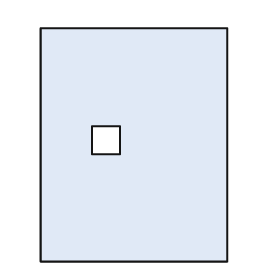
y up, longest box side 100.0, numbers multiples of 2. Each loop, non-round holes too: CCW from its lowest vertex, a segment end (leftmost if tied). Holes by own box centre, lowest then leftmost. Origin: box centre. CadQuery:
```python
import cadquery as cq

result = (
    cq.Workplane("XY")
    .moveTo(-40.0, -50.0)
    .lineTo(40.0, -50.0)
    .lineTo(40.0, 50.0)
    .lineTo(-40.0, 50.0)
    .close()
    .moveTo(-18.0, -4.0)
    .lineTo(-6.0, -4.0)
    .lineTo(-6.0, 8.0)
    .lineTo(-18.0, 8.0)
    .close()
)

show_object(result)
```